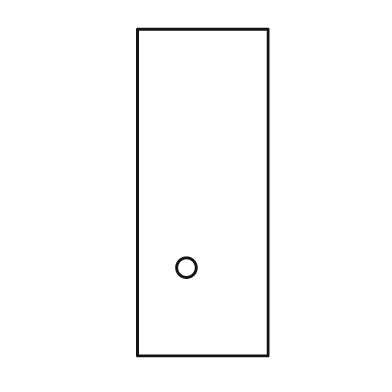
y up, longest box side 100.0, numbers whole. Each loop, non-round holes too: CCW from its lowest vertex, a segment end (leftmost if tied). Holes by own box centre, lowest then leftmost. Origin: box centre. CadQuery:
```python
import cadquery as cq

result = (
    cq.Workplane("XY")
    .moveTo(-20.0, -50.0)
    .lineTo(20.0, -50.0)
    .lineTo(20.0, 50.0)
    .lineTo(-20.0, 50.0)
    .close()
    .moveTo(-5.0, -23.0)
    .circle(3.0)
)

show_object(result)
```